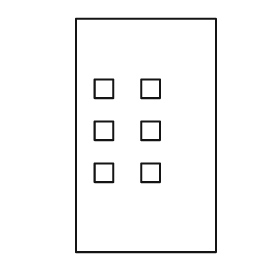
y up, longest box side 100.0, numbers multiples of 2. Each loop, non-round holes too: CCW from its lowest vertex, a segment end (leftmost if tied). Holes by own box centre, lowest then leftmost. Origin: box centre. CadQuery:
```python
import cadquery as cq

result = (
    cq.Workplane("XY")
    .moveTo(-30.0, -50.0)
    .lineTo(30.0, -50.0)
    .lineTo(30.0, 50.0)
    .lineTo(-30.0, 50.0)
    .close()
    .moveTo(-22.0, -20.0)
    .lineTo(-14.0, -20.0)
    .lineTo(-14.0, -12.0)
    .lineTo(-22.0, -12.0)
    .close()
    .moveTo(-2.0, -20.0)
    .lineTo(6.0, -20.0)
    .lineTo(6.0, -12.0)
    .lineTo(-2.0, -12.0)
    .close()
    .moveTo(-22.0, -2.0)
    .lineTo(-14.0, -2.0)
    .lineTo(-14.0, 6.0)
    .lineTo(-22.0, 6.0)
    .close()
    .moveTo(-2.0, -2.0)
    .lineTo(6.0, -2.0)
    .lineTo(6.0, 6.0)
    .lineTo(-2.0, 6.0)
    .close()
    .moveTo(-22.0, 16.0)
    .lineTo(-14.0, 16.0)
    .lineTo(-14.0, 24.0)
    .lineTo(-22.0, 24.0)
    .close()
    .moveTo(-2.0, 16.0)
    .lineTo(6.0, 16.0)
    .lineTo(6.0, 24.0)
    .lineTo(-2.0, 24.0)
    .close()
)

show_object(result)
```